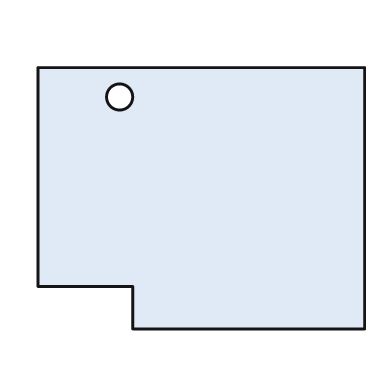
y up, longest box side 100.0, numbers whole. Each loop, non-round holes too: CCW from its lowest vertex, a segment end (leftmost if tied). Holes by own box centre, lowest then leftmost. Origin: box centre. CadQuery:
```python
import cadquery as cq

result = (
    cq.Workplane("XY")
    .moveTo(-21.0, -40.0)
    .lineTo(50.0, -40.0)
    .lineTo(50.0, 40.0)
    .lineTo(-50.0, 40.0)
    .lineTo(-50.0, -27.0)
    .lineTo(-21.0, -27.0)
    .close()
    .moveTo(-25.0, 31.0)
    .circle(4.0)
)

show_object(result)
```